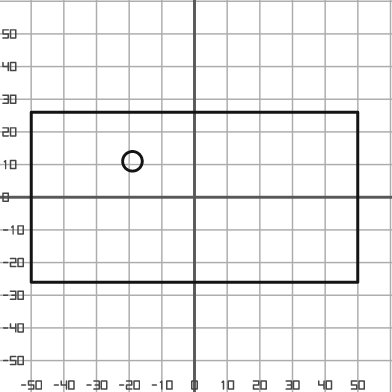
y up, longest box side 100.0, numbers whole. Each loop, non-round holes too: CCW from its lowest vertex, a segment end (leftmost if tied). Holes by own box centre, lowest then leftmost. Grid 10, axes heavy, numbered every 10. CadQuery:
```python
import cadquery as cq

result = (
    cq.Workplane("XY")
    .moveTo(-50.0, -26.0)
    .lineTo(50.0, -26.0)
    .lineTo(50.0, 26.0)
    .lineTo(-50.0, 26.0)
    .close()
    .moveTo(-19.0, 11.0)
    .circle(3.0)
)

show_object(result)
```